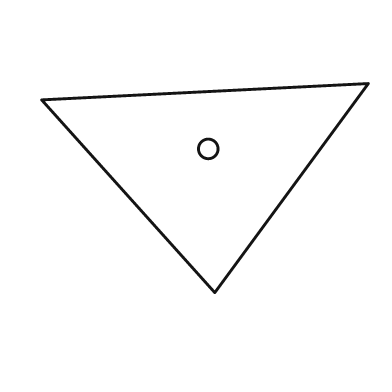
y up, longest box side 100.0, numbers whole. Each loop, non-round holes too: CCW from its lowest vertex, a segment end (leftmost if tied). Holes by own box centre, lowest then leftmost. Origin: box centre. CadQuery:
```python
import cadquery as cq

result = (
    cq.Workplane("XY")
    .moveTo(3.0, -32.0)
    .lineTo(50.0, 32.0)
    .lineTo(-50.0, 27.0)
    .close()
    .moveTo(1.0, 12.0)
    .circle(3.0)
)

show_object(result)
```